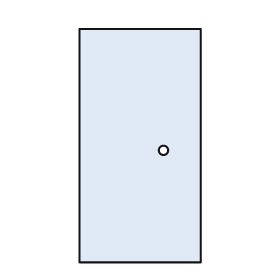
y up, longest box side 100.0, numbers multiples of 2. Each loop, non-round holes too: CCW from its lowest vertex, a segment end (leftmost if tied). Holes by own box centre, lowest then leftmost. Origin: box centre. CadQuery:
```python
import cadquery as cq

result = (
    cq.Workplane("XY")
    .moveTo(-26.0, -50.0)
    .lineTo(26.0, -50.0)
    .lineTo(26.0, 50.0)
    .lineTo(-26.0, 50.0)
    .close()
    .moveTo(10.0, -2.0)
    .circle(2.0)
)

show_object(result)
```